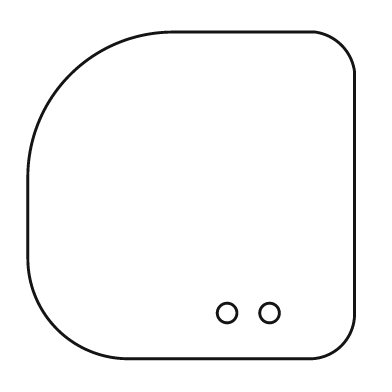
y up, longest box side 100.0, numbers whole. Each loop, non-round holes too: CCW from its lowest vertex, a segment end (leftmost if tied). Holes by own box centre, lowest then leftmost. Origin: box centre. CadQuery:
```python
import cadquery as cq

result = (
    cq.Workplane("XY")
    .moveTo(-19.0, -50.0)
    .lineTo(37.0, -50.0)
    .threePointArc((46.0, -46.0), (50.0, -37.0))
    .lineTo(50.0, 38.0)
    .threePointArc((46.0, 46.0), (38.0, 50.0))
    .lineTo(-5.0, 50.0)
    .threePointArc((-37.0, 37.0), (-50.0, 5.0))
    .lineTo(-50.0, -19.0)
    .threePointArc((-41.0, -41.0), (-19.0, -50.0))
    .close()
    .moveTo(11.0, -36.0)
    .circle(3.0)
    .moveTo(24.0, -36.0)
    .circle(3.0)
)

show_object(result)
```